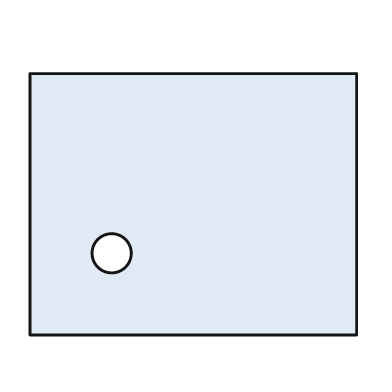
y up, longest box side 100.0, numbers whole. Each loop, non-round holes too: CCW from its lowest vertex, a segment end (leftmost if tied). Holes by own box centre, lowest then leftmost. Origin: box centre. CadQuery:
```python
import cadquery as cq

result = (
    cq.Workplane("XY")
    .moveTo(-50.0, -40.0)
    .lineTo(50.0, -40.0)
    .lineTo(50.0, 40.0)
    .lineTo(-50.0, 40.0)
    .close()
    .moveTo(-25.0, -15.0)
    .circle(6.0)
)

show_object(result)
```